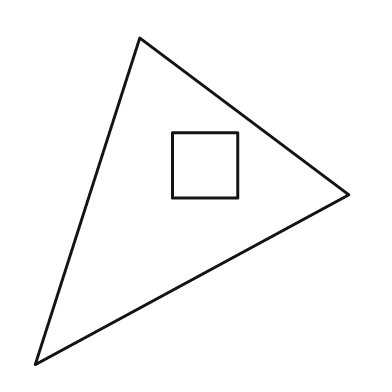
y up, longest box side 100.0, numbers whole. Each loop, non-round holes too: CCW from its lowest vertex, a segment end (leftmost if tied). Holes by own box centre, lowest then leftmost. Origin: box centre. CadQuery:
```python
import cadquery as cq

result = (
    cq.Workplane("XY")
    .moveTo(-48.0, -50.0)
    .lineTo(48.0, 2.0)
    .lineTo(-16.0, 50.0)
    .close()
    .moveTo(-6.0, 1.0)
    .lineTo(14.0, 1.0)
    .lineTo(14.0, 21.0)
    .lineTo(-6.0, 21.0)
    .close()
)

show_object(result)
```